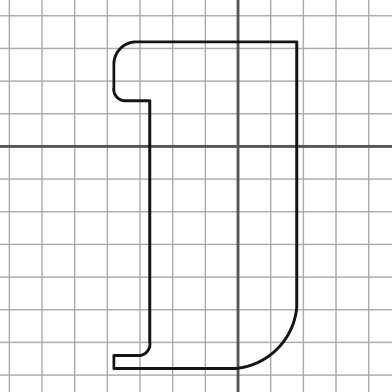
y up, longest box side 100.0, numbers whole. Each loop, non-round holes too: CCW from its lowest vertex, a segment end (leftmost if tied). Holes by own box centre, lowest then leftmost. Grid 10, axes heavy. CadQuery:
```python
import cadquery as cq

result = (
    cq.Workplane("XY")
    .moveTo(-38.0, -68.0)
    .lineTo(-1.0, -68.0)
    .threePointArc((12.0, -62.0), (18.0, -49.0))
    .lineTo(18.0, 32.0)
    .lineTo(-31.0, 32.0)
    .threePointArc((-36.0, 30.0), (-38.0, 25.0))
    .lineTo(-38.0, 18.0)
    .threePointArc((-37.0, 15.0), (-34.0, 14.0))
    .lineTo(-27.0, 14.0)
    .lineTo(-27.0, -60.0)
    .threePointArc((-28.0, -63.0), (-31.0, -64.0))
    .lineTo(-38.0, -64.0)
    .close()
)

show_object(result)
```